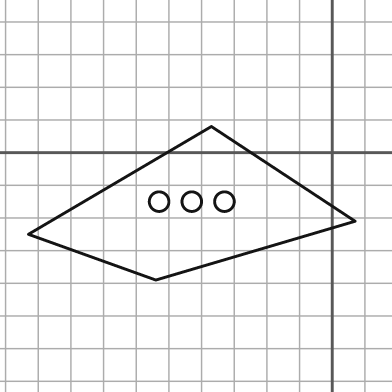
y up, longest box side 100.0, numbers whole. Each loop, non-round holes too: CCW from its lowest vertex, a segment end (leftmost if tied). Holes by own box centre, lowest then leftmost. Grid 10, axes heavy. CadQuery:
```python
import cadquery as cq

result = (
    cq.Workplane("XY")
    .moveTo(-54.0, -39.0)
    .lineTo(7.0, -21.0)
    .lineTo(-37.0, 8.0)
    .lineTo(-93.0, -25.0)
    .close()
    .moveTo(-53.0, -15.0)
    .circle(3.0)
    .moveTo(-43.0, -15.0)
    .circle(3.0)
    .moveTo(-33.0, -15.0)
    .circle(3.0)
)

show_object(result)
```